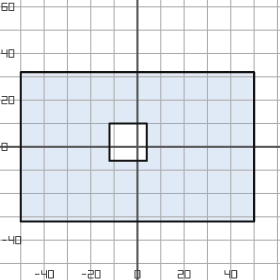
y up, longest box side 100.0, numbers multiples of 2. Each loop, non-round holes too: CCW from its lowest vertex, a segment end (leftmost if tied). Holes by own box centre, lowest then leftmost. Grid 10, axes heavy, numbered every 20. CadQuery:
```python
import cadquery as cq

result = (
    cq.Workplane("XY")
    .moveTo(-50.0, -32.0)
    .lineTo(50.0, -32.0)
    .lineTo(50.0, 32.0)
    .lineTo(-50.0, 32.0)
    .close()
    .moveTo(-12.0, -6.0)
    .lineTo(4.0, -6.0)
    .lineTo(4.0, 10.0)
    .lineTo(-12.0, 10.0)
    .close()
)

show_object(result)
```